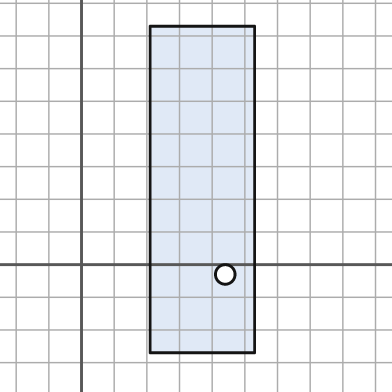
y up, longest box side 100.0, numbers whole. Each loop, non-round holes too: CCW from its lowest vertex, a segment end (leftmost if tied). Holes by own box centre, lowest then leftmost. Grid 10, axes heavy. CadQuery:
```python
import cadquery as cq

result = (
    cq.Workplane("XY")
    .moveTo(21.0, -27.0)
    .lineTo(53.0, -27.0)
    .lineTo(53.0, 73.0)
    .lineTo(21.0, 73.0)
    .close()
    .moveTo(44.0, -3.0)
    .circle(3.0)
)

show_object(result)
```